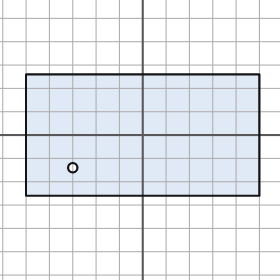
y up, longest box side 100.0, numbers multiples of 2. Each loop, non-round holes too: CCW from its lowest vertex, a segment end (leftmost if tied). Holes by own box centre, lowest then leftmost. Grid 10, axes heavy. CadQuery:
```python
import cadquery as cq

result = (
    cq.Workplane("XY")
    .moveTo(-50.0, -26.0)
    .lineTo(50.0, -26.0)
    .lineTo(50.0, 26.0)
    .lineTo(-50.0, 26.0)
    .close()
    .moveTo(-30.0, -14.0)
    .circle(2.0)
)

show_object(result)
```